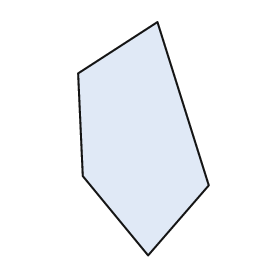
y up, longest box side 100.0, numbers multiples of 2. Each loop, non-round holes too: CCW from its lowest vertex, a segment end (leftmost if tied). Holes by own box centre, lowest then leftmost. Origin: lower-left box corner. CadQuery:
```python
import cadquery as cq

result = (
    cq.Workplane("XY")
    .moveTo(30.0, 0.0)
    .lineTo(56.0, 30.0)
    .lineTo(34.0, 100.0)
    .lineTo(0.0, 78.0)
    .lineTo(2.0, 34.0)
    .close()
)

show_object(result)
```